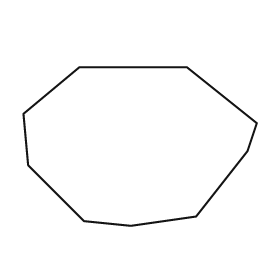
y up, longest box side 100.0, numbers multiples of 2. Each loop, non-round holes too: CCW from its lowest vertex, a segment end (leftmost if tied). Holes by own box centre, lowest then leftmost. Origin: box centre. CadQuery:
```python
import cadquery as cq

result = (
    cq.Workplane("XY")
    .moveTo(-4.0, -34.0)
    .lineTo(24.0, -30.0)
    .lineTo(46.0, -2.0)
    .lineTo(50.0, 10.0)
    .lineTo(20.0, 34.0)
    .lineTo(-26.0, 34.0)
    .lineTo(-50.0, 14.0)
    .lineTo(-48.0, -8.0)
    .lineTo(-24.0, -32.0)
    .close()
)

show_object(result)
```